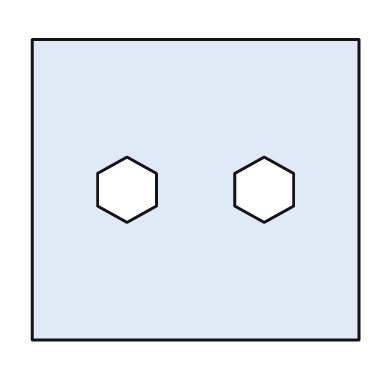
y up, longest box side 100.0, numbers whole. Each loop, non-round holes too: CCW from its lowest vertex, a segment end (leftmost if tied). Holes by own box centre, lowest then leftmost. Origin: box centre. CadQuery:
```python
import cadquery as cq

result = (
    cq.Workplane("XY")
    .moveTo(-50.0, -46.0)
    .lineTo(50.0, -46.0)
    .lineTo(50.0, 46.0)
    .lineTo(-50.0, 46.0)
    .close()
    .moveTo(-21.0, -10.0)
    .lineTo(-12.0, -5.0)
    .lineTo(-12.0, 5.0)
    .lineTo(-21.0, 10.0)
    .lineTo(-30.0, 5.0)
    .lineTo(-30.0, -5.0)
    .close()
    .moveTo(21.0, -10.0)
    .lineTo(30.0, -5.0)
    .lineTo(30.0, 5.0)
    .lineTo(21.0, 10.0)
    .lineTo(12.0, 5.0)
    .lineTo(12.0, -5.0)
    .close()
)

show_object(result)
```